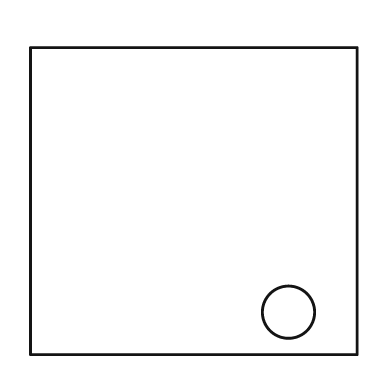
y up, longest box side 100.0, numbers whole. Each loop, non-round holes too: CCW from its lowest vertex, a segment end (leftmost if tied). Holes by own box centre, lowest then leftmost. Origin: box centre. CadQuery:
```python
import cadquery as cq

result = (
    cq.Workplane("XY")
    .moveTo(-50.0, -47.0)
    .lineTo(50.0, -47.0)
    .lineTo(50.0, 47.0)
    .lineTo(-50.0, 47.0)
    .close()
    .moveTo(29.0, -34.0)
    .circle(8.0)
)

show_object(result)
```